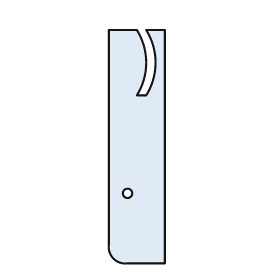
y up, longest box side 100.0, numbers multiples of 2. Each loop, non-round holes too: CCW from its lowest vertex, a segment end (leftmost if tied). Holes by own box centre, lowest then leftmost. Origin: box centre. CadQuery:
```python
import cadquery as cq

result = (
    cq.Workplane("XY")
    .moveTo(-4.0, -50.0)
    .lineTo(12.0, -50.0)
    .lineTo(12.0, 50.0)
    .lineTo(4.0, 50.0)
    .threePointArc((8.0, 36.0), (4.0, 22.0))
    .lineTo(0.0, 22.0)
    .threePointArc((4.0, 36.0), (0.0, 50.0))
    .lineTo(-12.0, 50.0)
    .lineTo(-12.0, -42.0)
    .threePointArc((-10.0, -48.0), (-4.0, -50.0))
    .close()
    .moveTo(-4.0, -20.0)
    .circle(2.0)
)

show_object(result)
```